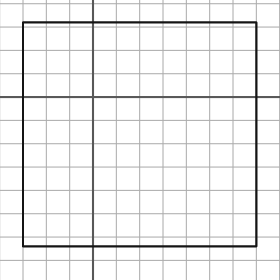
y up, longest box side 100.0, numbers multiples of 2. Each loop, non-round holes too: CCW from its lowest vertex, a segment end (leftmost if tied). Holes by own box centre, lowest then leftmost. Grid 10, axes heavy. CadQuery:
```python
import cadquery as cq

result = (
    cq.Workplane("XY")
    .moveTo(-30.0, -64.0)
    .lineTo(70.0, -64.0)
    .lineTo(70.0, 32.0)
    .lineTo(-30.0, 32.0)
    .close()
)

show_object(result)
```